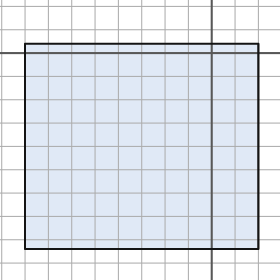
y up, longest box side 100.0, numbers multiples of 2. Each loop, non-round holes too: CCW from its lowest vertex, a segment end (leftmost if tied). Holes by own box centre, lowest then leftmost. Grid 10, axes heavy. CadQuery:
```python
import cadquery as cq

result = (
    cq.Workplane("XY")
    .moveTo(-80.0, -84.0)
    .lineTo(20.0, -84.0)
    .lineTo(20.0, 4.0)
    .lineTo(-80.0, 4.0)
    .close()
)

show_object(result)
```